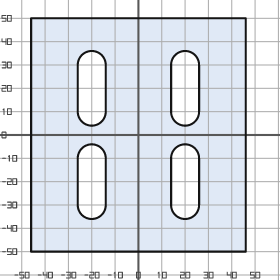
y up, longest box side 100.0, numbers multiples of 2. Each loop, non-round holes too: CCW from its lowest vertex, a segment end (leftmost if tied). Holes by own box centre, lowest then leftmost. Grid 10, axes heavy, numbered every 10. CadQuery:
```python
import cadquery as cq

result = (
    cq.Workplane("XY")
    .moveTo(-46.0, -50.0)
    .lineTo(46.0, -50.0)
    .lineTo(46.0, 50.0)
    .lineTo(-46.0, 50.0)
    .close()
    .moveTo(-26.0, -30.0)
    .threePointArc((-20.0, -36.0), (-14.0, -30.0))
    .lineTo(-14.0, -10.0)
    .threePointArc((-20.0, -4.0), (-26.0, -10.0))
    .close()
    .moveTo(14.0, -30.0)
    .threePointArc((20.0, -36.0), (26.0, -30.0))
    .lineTo(26.0, -10.0)
    .threePointArc((20.0, -4.0), (14.0, -10.0))
    .close()
    .moveTo(-26.0, 10.0)
    .threePointArc((-20.0, 4.0), (-14.0, 10.0))
    .lineTo(-14.0, 30.0)
    .threePointArc((-20.0, 36.0), (-26.0, 30.0))
    .close()
    .moveTo(14.0, 10.0)
    .threePointArc((20.0, 4.0), (26.0, 10.0))
    .lineTo(26.0, 30.0)
    .threePointArc((20.0, 36.0), (14.0, 30.0))
    .close()
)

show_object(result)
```